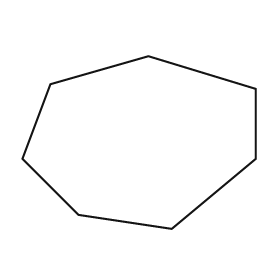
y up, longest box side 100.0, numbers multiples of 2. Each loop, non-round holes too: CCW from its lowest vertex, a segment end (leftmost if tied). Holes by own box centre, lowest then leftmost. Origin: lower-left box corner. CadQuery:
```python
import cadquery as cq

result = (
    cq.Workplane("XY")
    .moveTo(64.0, 0.0)
    .lineTo(100.0, 30.0)
    .lineTo(100.0, 60.0)
    .lineTo(54.0, 74.0)
    .lineTo(12.0, 62.0)
    .lineTo(0.0, 30.0)
    .lineTo(24.0, 6.0)
    .close()
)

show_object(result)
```